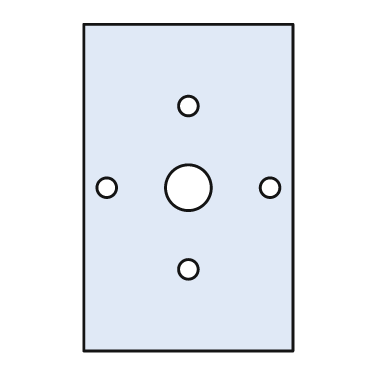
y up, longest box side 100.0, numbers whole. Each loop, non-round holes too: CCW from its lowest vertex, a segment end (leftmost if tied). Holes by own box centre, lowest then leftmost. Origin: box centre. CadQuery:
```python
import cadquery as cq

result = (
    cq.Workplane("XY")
    .moveTo(-32.0, -50.0)
    .lineTo(32.0, -50.0)
    .lineTo(32.0, 50.0)
    .lineTo(-32.0, 50.0)
    .close()
    .moveTo(0.0, -25.0)
    .circle(3.0)
    .moveTo(-25.0, 0.0)
    .circle(3.0)
    .moveTo(0.0, 0.0)
    .circle(7.0)
    .moveTo(25.0, 0.0)
    .circle(3.0)
    .moveTo(0.0, 25.0)
    .circle(3.0)
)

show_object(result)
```